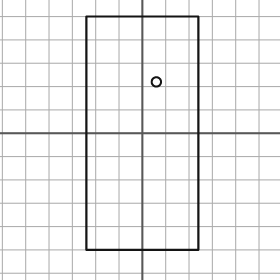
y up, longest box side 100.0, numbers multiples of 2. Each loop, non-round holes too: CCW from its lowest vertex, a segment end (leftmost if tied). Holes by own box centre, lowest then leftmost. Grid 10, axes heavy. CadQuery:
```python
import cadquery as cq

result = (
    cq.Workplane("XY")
    .moveTo(-24.0, -50.0)
    .lineTo(24.0, -50.0)
    .lineTo(24.0, 50.0)
    .lineTo(-24.0, 50.0)
    .close()
    .moveTo(6.0, 22.0)
    .circle(2.0)
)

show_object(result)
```